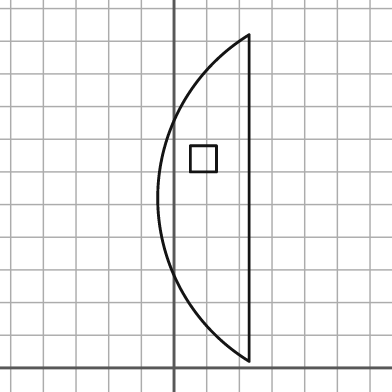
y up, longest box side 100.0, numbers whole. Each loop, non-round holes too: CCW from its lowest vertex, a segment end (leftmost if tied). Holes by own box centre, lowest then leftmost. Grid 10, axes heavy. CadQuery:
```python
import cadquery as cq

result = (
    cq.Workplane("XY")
    .moveTo(23.0, 2.0)
    .lineTo(23.0, 102.0)
    .threePointArc((-5.0, 52.0), (23.0, 2.0))
    .close()
    .moveTo(5.0, 60.0)
    .lineTo(13.0, 60.0)
    .lineTo(13.0, 68.0)
    .lineTo(5.0, 68.0)
    .close()
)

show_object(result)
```